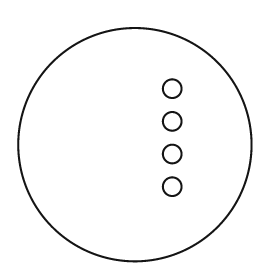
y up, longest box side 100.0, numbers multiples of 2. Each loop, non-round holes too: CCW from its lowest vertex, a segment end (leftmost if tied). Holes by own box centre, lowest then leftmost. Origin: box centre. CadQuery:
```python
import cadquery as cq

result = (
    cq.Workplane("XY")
    .moveTo(0.0, 0.0)
    .circle(50.0)
    .moveTo(16.0, -18.0)
    .circle(4.0)
    .moveTo(16.0, -4.0)
    .circle(4.0)
    .moveTo(16.0, 10.0)
    .circle(4.0)
    .moveTo(16.0, 24.0)
    .circle(4.0)
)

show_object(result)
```